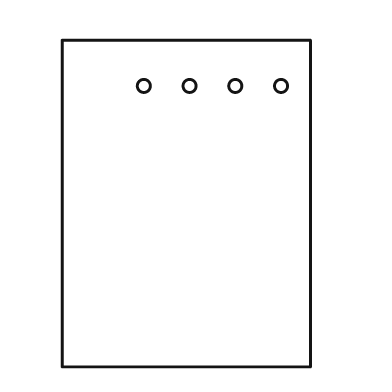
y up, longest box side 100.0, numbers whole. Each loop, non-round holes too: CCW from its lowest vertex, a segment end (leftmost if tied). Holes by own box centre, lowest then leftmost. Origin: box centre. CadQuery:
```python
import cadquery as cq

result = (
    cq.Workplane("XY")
    .moveTo(-38.0, -50.0)
    .lineTo(38.0, -50.0)
    .lineTo(38.0, 50.0)
    .lineTo(-38.0, 50.0)
    .close()
    .moveTo(-13.0, 36.0)
    .circle(2.0)
    .moveTo(1.0, 36.0)
    .circle(2.0)
    .moveTo(15.0, 36.0)
    .circle(2.0)
    .moveTo(29.0, 36.0)
    .circle(2.0)
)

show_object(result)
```